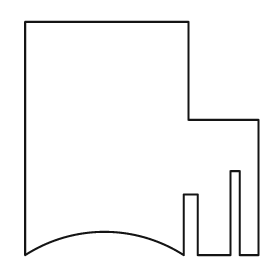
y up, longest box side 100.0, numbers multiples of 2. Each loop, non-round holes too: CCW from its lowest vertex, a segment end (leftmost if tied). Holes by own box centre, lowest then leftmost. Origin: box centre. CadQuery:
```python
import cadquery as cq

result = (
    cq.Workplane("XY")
    .moveTo(-50.0, -50.0)
    .threePointArc((-16.0, -40.0), (18.0, -50.0))
    .lineTo(18.0, -24.0)
    .lineTo(24.0, -24.0)
    .lineTo(24.0, -50.0)
    .lineTo(38.0, -50.0)
    .lineTo(38.0, -14.0)
    .lineTo(42.0, -14.0)
    .lineTo(42.0, -50.0)
    .lineTo(50.0, -50.0)
    .lineTo(50.0, 8.0)
    .lineTo(20.0, 8.0)
    .lineTo(20.0, 50.0)
    .lineTo(-50.0, 50.0)
    .close()
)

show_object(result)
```